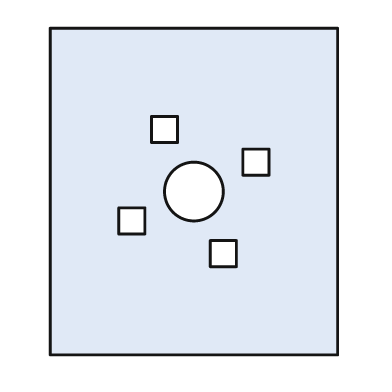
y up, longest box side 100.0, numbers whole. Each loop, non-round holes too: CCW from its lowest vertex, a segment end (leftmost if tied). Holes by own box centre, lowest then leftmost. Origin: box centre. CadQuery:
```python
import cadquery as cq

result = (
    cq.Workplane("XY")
    .moveTo(-44.0, -50.0)
    .lineTo(44.0, -50.0)
    .lineTo(44.0, 50.0)
    .lineTo(-44.0, 50.0)
    .close()
    .moveTo(5.0, -23.0)
    .lineTo(13.0, -23.0)
    .lineTo(13.0, -15.0)
    .lineTo(5.0, -15.0)
    .close()
    .moveTo(-23.0, -13.0)
    .lineTo(-15.0, -13.0)
    .lineTo(-15.0, -5.0)
    .lineTo(-23.0, -5.0)
    .close()
    .moveTo(0.0, 0.0)
    .circle(9.0)
    .moveTo(15.0, 5.0)
    .lineTo(23.0, 5.0)
    .lineTo(23.0, 13.0)
    .lineTo(15.0, 13.0)
    .close()
    .moveTo(-13.0, 15.0)
    .lineTo(-5.0, 15.0)
    .lineTo(-5.0, 23.0)
    .lineTo(-13.0, 23.0)
    .close()
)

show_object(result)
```